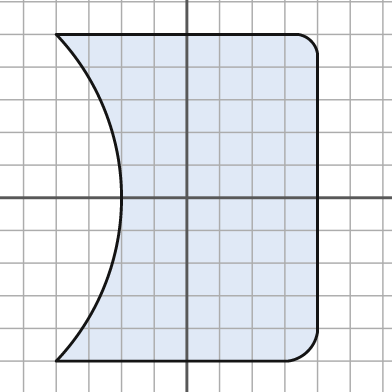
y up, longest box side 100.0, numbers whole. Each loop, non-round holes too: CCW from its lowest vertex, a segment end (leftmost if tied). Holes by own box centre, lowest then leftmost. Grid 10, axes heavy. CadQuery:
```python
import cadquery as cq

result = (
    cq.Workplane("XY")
    .moveTo(-40.0, -50.0)
    .lineTo(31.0, -50.0)
    .threePointArc((37.0, -47.0), (40.0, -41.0))
    .lineTo(40.0, 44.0)
    .threePointArc((38.0, 48.0), (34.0, 50.0))
    .lineTo(-40.0, 50.0)
    .threePointArc((-20.0, 0.0), (-40.0, -50.0))
    .close()
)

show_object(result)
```